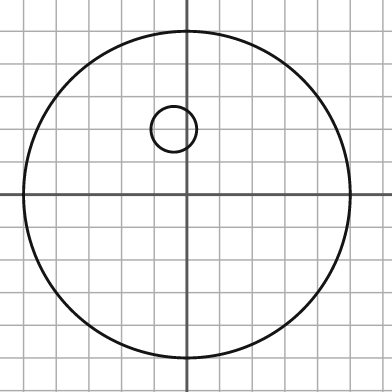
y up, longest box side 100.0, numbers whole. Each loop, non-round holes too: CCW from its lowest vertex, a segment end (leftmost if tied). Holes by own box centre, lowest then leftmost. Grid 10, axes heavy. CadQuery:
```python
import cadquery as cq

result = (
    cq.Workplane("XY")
    .moveTo(0.0, 0.0)
    .circle(50.0)
    .moveTo(-4.0, 20.0)
    .circle(7.0)
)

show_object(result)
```